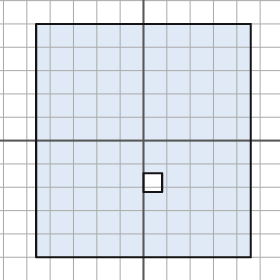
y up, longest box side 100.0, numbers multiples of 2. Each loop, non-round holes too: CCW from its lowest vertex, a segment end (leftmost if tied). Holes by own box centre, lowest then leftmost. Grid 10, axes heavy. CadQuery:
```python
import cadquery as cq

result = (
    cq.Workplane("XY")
    .moveTo(-46.0, -50.0)
    .lineTo(46.0, -50.0)
    .lineTo(46.0, 50.0)
    .lineTo(-46.0, 50.0)
    .close()
    .moveTo(0.0, -22.0)
    .lineTo(8.0, -22.0)
    .lineTo(8.0, -14.0)
    .lineTo(0.0, -14.0)
    .close()
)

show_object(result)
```